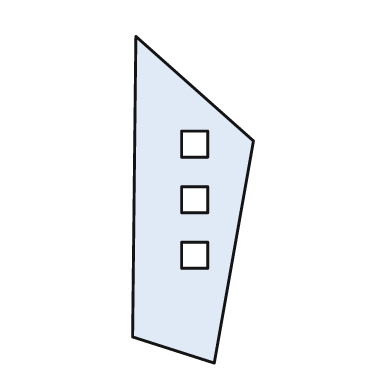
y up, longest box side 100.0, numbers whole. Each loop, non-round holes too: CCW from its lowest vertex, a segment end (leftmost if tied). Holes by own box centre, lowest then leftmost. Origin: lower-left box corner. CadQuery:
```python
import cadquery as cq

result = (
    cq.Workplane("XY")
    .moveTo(25.0, 0.0)
    .lineTo(37.0, 68.0)
    .lineTo(1.0, 100.0)
    .lineTo(0.0, 8.0)
    .close()
    .moveTo(15.0, 29.0)
    .lineTo(23.0, 29.0)
    .lineTo(23.0, 37.0)
    .lineTo(15.0, 37.0)
    .close()
    .moveTo(15.0, 46.0)
    .lineTo(23.0, 46.0)
    .lineTo(23.0, 54.0)
    .lineTo(15.0, 54.0)
    .close()
    .moveTo(15.0, 63.0)
    .lineTo(23.0, 63.0)
    .lineTo(23.0, 71.0)
    .lineTo(15.0, 71.0)
    .close()
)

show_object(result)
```